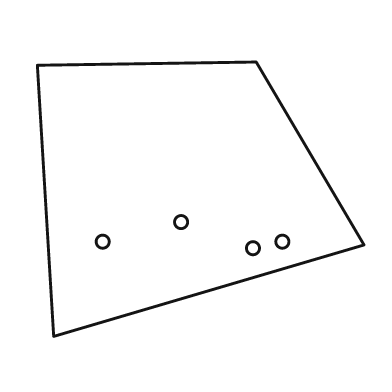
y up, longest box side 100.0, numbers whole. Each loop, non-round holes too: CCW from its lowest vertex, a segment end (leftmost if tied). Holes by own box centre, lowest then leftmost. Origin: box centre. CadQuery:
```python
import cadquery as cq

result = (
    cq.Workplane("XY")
    .moveTo(-45.0, -42.0)
    .lineTo(50.0, -14.0)
    .lineTo(17.0, 42.0)
    .lineTo(-50.0, 41.0)
    .close()
    .moveTo(16.0, -15.0)
    .circle(2.0)
    .moveTo(-30.0, -13.0)
    .circle(2.0)
    .moveTo(25.0, -13.0)
    .circle(2.0)
    .moveTo(-6.0, -7.0)
    .circle(2.0)
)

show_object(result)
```